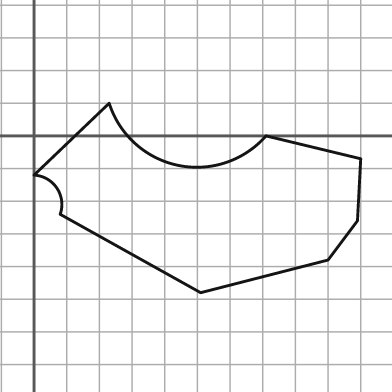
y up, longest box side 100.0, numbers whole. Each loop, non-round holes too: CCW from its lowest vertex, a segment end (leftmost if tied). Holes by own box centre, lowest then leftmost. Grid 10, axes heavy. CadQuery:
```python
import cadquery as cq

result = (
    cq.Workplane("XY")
    .moveTo(51.0, -48.0)
    .lineTo(90.0, -38.0)
    .lineTo(99.0, -26.0)
    .lineTo(100.0, -7.0)
    .lineTo(71.0, 0.0)
    .threePointArc((44.0, -9.0), (23.0, 10.0))
    .lineTo(0.0, -12.0)
    .threePointArc((7.0, -16.0), (8.0, -24.0))
    .close()
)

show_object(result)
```